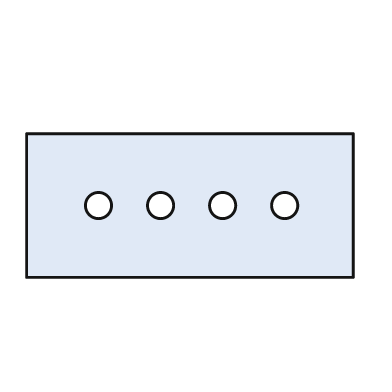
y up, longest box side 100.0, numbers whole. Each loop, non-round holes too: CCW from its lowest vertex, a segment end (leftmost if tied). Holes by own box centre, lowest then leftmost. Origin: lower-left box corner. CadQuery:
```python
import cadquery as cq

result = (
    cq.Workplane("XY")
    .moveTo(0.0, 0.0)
    .lineTo(100.0, 0.0)
    .lineTo(100.0, 44.0)
    .lineTo(0.0, 44.0)
    .close()
    .moveTo(22.0, 22.0)
    .circle(4.0)
    .moveTo(41.0, 22.0)
    .circle(4.0)
    .moveTo(60.0, 22.0)
    .circle(4.0)
    .moveTo(79.0, 22.0)
    .circle(4.0)
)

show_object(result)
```